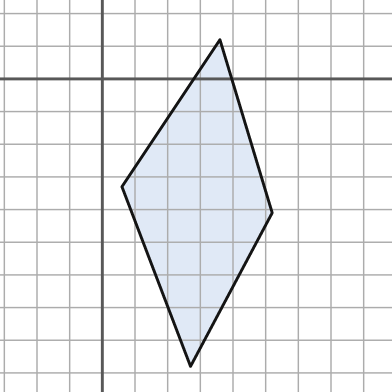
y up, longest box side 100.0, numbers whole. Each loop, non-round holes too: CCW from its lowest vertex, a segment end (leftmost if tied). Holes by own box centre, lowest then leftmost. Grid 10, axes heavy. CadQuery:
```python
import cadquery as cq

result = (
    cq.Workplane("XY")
    .moveTo(27.0, -88.0)
    .lineTo(52.0, -41.0)
    .lineTo(36.0, 12.0)
    .lineTo(6.0, -33.0)
    .close()
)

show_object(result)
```